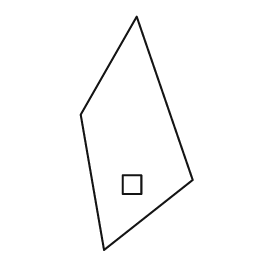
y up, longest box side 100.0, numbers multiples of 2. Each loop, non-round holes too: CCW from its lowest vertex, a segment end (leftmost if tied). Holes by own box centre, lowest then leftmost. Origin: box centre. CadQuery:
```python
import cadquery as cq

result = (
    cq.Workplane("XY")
    .moveTo(-14.0, -50.0)
    .lineTo(24.0, -20.0)
    .lineTo(0.0, 50.0)
    .lineTo(-24.0, 8.0)
    .close()
    .moveTo(-6.0, -26.0)
    .lineTo(2.0, -26.0)
    .lineTo(2.0, -18.0)
    .lineTo(-6.0, -18.0)
    .close()
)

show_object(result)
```